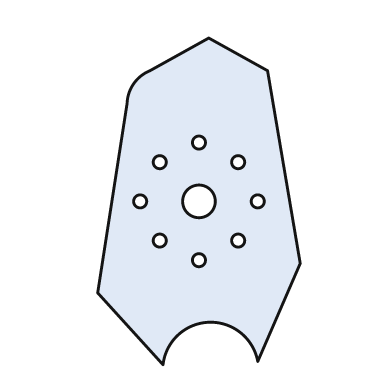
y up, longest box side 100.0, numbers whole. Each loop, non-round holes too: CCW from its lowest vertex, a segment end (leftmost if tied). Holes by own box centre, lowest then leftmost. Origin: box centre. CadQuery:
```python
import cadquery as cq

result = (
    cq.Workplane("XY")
    .moveTo(-11.0, -50.0)
    .threePointArc((3.0, -37.0), (18.0, -49.0))
    .lineTo(31.0, -19.0)
    .lineTo(21.0, 40.0)
    .lineTo(3.0, 50.0)
    .lineTo(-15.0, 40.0)
    .threePointArc((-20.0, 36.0), (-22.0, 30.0))
    .lineTo(-31.0, -28.0)
    .close()
    .moveTo(0.0, -18.0)
    .circle(2.0)
    .moveTo(-12.0, -12.0)
    .circle(2.0)
    .moveTo(12.0, -12.0)
    .circle(2.0)
    .moveTo(-18.0, 0.0)
    .circle(2.0)
    .moveTo(0.0, 0.0)
    .circle(5.0)
    .moveTo(18.0, 0.0)
    .circle(2.0)
    .moveTo(-12.0, 12.0)
    .circle(2.0)
    .moveTo(12.0, 12.0)
    .circle(2.0)
    .moveTo(0.0, 18.0)
    .circle(2.0)
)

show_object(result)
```